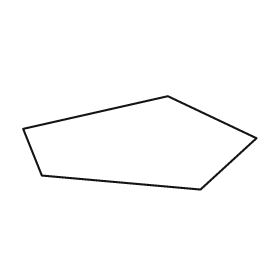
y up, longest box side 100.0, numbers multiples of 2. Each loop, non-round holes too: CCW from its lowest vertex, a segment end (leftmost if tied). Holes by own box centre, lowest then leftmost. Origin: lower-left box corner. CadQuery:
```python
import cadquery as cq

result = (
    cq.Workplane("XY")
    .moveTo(76.0, 0.0)
    .lineTo(100.0, 22.0)
    .lineTo(62.0, 40.0)
    .lineTo(0.0, 26.0)
    .lineTo(8.0, 6.0)
    .close()
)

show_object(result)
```